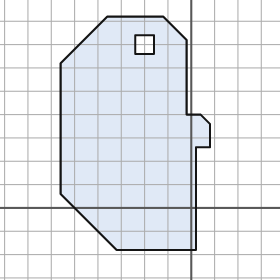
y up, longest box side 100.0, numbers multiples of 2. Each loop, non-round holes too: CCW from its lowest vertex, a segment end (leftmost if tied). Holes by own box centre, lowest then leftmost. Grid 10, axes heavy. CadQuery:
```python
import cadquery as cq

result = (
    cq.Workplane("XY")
    .moveTo(-32.0, -18.0)
    .lineTo(2.0, -18.0)
    .lineTo(2.0, 26.0)
    .lineTo(8.0, 26.0)
    .lineTo(8.0, 36.0)
    .lineTo(4.0, 40.0)
    .lineTo(-2.0, 40.0)
    .lineTo(-2.0, 72.0)
    .lineTo(-12.0, 82.0)
    .lineTo(-36.0, 82.0)
    .lineTo(-56.0, 62.0)
    .lineTo(-56.0, 6.0)
    .close()
    .moveTo(-24.0, 66.0)
    .lineTo(-16.0, 66.0)
    .lineTo(-16.0, 74.0)
    .lineTo(-24.0, 74.0)
    .close()
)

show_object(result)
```